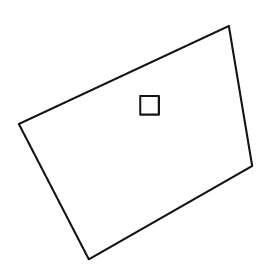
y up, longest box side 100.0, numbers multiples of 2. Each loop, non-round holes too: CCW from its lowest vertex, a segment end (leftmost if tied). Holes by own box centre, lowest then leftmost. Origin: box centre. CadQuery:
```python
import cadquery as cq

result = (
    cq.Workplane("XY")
    .moveTo(-20.0, -50.0)
    .lineTo(50.0, -10.0)
    .lineTo(40.0, 50.0)
    .lineTo(-50.0, 8.0)
    .close()
    .moveTo(2.0, 12.0)
    .lineTo(10.0, 12.0)
    .lineTo(10.0, 20.0)
    .lineTo(2.0, 20.0)
    .close()
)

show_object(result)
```